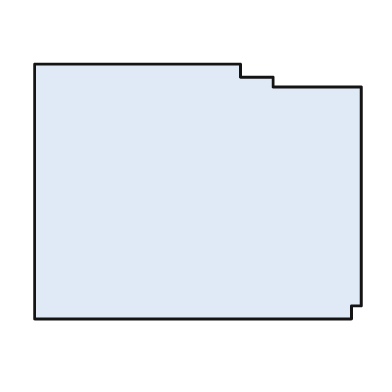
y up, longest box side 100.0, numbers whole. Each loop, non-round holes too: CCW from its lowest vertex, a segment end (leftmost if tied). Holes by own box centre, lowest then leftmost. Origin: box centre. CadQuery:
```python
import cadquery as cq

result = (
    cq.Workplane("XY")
    .moveTo(-50.0, -39.0)
    .lineTo(47.0, -39.0)
    .lineTo(47.0, -35.0)
    .lineTo(50.0, -35.0)
    .lineTo(50.0, 32.0)
    .lineTo(23.0, 32.0)
    .lineTo(23.0, 35.0)
    .lineTo(13.0, 35.0)
    .lineTo(13.0, 39.0)
    .lineTo(-50.0, 39.0)
    .close()
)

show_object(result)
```